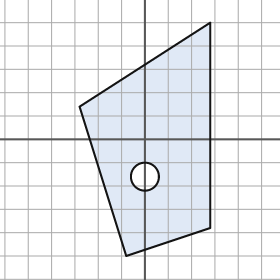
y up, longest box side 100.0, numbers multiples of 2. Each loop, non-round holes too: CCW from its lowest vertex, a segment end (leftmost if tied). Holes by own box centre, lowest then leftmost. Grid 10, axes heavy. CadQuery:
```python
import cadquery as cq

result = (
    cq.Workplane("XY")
    .moveTo(-8.0, -50.0)
    .lineTo(28.0, -38.0)
    .lineTo(28.0, 50.0)
    .lineTo(-28.0, 14.0)
    .close()
    .moveTo(0.0, -16.0)
    .circle(6.0)
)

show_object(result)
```